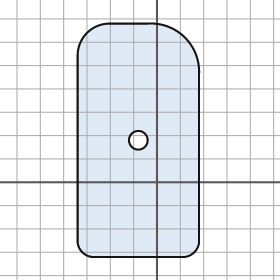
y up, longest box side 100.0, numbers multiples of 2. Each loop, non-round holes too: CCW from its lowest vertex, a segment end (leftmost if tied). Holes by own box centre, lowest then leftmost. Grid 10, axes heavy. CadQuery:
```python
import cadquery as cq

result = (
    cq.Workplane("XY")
    .moveTo(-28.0, -32.0)
    .lineTo(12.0, -32.0)
    .threePointArc((16.0, -30.0), (18.0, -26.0))
    .lineTo(18.0, 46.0)
    .threePointArc((12.0, 62.0), (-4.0, 68.0))
    .lineTo(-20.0, 68.0)
    .threePointArc((-30.0, 64.0), (-34.0, 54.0))
    .lineTo(-34.0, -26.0)
    .threePointArc((-32.0, -30.0), (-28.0, -32.0))
    .close()
    .moveTo(-8.0, 18.0)
    .circle(4.0)
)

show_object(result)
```